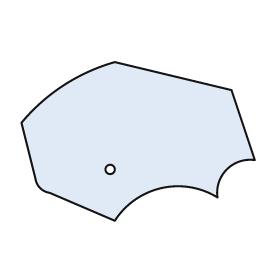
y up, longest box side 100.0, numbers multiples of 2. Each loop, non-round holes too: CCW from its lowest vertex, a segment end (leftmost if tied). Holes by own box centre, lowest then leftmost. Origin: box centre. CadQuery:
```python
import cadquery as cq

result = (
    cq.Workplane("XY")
    .moveTo(-10.0, -34.0)
    .threePointArc((10.0, -20.0), (34.0, -24.0))
    .threePointArc((38.0, -12.0), (50.0, -8.0))
    .lineTo(40.0, 22.0)
    .lineTo(-10.0, 34.0)
    .threePointArc((-32.0, 24.0), (-50.0, 8.0))
    .lineTo(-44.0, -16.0)
    .threePointArc((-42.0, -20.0), (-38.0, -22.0))
    .close()
    .moveTo(-12.0, -12.0)
    .circle(2.0)
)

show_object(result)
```